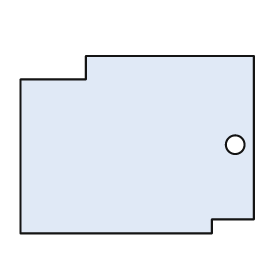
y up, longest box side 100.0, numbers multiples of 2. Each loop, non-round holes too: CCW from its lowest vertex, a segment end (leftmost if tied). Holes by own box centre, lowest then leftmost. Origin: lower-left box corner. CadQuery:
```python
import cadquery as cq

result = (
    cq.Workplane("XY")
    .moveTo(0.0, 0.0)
    .lineTo(82.0, 0.0)
    .lineTo(82.0, 6.0)
    .lineTo(100.0, 6.0)
    .lineTo(100.0, 76.0)
    .lineTo(28.0, 76.0)
    .lineTo(28.0, 66.0)
    .lineTo(0.0, 66.0)
    .close()
    .moveTo(92.0, 38.0)
    .circle(4.0)
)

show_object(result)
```